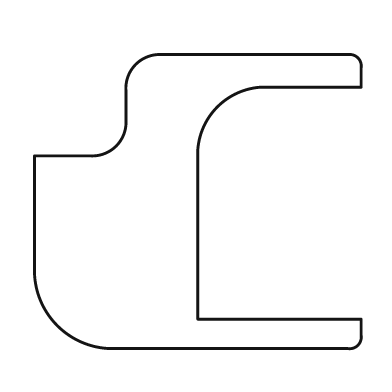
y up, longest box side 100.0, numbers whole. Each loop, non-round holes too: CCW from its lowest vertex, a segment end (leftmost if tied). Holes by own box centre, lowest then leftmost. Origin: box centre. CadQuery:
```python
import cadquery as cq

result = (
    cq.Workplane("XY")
    .moveTo(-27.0, -45.0)
    .lineTo(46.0, -45.0)
    .threePointArc((49.0, -44.0), (50.0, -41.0))
    .lineTo(50.0, -36.0)
    .lineTo(0.0, -36.0)
    .lineTo(0.0, 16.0)
    .threePointArc((6.0, 29.0), (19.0, 35.0))
    .lineTo(50.0, 35.0)
    .lineTo(50.0, 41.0)
    .threePointArc((49.0, 44.0), (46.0, 45.0))
    .lineTo(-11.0, 45.0)
    .threePointArc((-19.0, 42.0), (-22.0, 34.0))
    .lineTo(-22.0, 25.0)
    .threePointArc((-25.0, 17.0), (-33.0, 14.0))
    .lineTo(-50.0, 14.0)
    .lineTo(-50.0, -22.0)
    .threePointArc((-43.0, -38.0), (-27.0, -45.0))
    .close()
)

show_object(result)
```